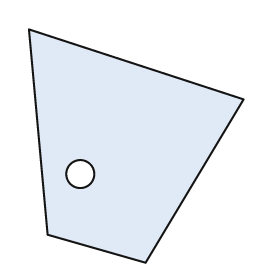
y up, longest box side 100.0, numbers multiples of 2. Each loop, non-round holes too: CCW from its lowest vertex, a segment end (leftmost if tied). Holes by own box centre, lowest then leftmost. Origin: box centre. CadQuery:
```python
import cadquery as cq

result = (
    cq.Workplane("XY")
    .moveTo(4.0, -50.0)
    .lineTo(46.0, 20.0)
    .lineTo(-46.0, 50.0)
    .lineTo(-38.0, -38.0)
    .close()
    .moveTo(-24.0, -12.0)
    .circle(6.0)
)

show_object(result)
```